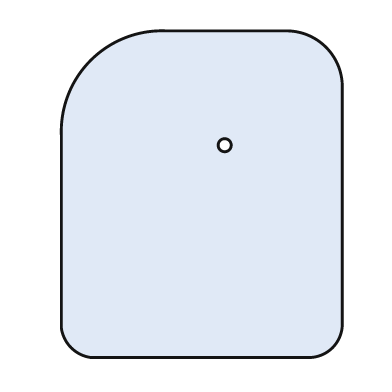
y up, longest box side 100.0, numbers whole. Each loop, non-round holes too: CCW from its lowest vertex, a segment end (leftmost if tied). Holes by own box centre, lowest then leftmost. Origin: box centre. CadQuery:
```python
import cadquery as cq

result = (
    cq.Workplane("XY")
    .moveTo(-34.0, -50.0)
    .lineTo(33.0, -50.0)
    .threePointArc((40.0, -47.0), (43.0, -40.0))
    .lineTo(43.0, 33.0)
    .threePointArc((38.0, 45.0), (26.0, 50.0))
    .lineTo(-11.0, 50.0)
    .threePointArc((-34.0, 41.0), (-43.0, 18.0))
    .lineTo(-43.0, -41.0)
    .threePointArc((-40.0, -47.0), (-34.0, -50.0))
    .close()
    .moveTo(7.0, 15.0)
    .circle(2.0)
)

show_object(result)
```